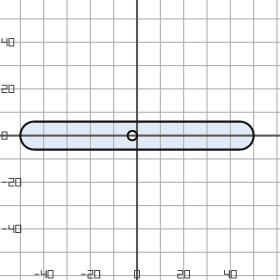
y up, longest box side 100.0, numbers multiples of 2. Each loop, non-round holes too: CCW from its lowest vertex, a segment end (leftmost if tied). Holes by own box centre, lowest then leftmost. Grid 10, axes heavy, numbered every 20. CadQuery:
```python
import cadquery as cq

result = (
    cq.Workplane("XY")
    .moveTo(-44.0, -6.0)
    .lineTo(44.0, -6.0)
    .threePointArc((50.0, 0.0), (44.0, 6.0))
    .lineTo(-44.0, 6.0)
    .threePointArc((-50.0, 0.0), (-44.0, -6.0))
    .close()
    .moveTo(-2.0, 0.0)
    .circle(2.0)
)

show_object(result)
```